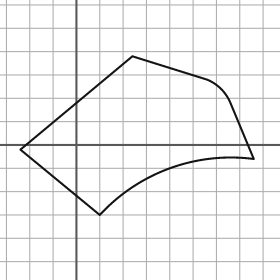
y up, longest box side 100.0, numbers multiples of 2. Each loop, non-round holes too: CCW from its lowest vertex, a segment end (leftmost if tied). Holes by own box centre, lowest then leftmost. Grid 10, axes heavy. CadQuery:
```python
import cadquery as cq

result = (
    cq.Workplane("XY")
    .moveTo(10.0, -30.0)
    .threePointArc((40.0, -10.0), (76.0, -6.0))
    .lineTo(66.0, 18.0)
    .threePointArc((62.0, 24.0), (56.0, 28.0))
    .lineTo(24.0, 38.0)
    .lineTo(-24.0, -2.0)
    .close()
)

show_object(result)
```